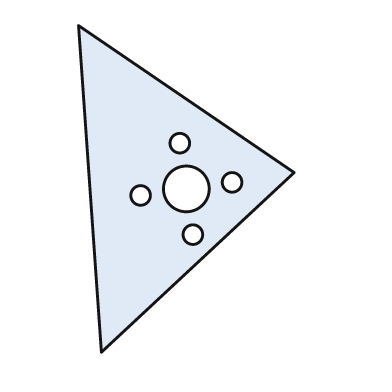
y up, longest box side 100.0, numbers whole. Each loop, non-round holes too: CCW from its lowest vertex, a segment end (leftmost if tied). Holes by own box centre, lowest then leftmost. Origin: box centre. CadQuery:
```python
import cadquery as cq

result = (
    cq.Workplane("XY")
    .moveTo(-26.0, -50.0)
    .lineTo(33.0, 5.0)
    .lineTo(-33.0, 50.0)
    .close()
    .moveTo(2.0, -14.0)
    .circle(3.0)
    .moveTo(-14.0, -2.0)
    .circle(3.0)
    .moveTo(0.0, 0.0)
    .circle(7.0)
    .moveTo(14.0, 2.0)
    .circle(3.0)
    .moveTo(-2.0, 14.0)
    .circle(3.0)
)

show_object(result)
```